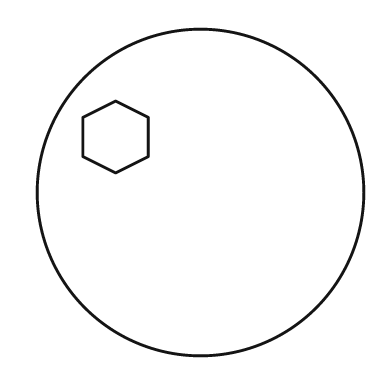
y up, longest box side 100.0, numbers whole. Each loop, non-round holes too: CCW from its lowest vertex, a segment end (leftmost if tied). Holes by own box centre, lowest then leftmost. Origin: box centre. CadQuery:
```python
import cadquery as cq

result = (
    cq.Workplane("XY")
    .moveTo(0.0, 0.0)
    .circle(50.0)
    .moveTo(-26.0, 6.0)
    .lineTo(-16.0, 11.0)
    .lineTo(-16.0, 23.0)
    .lineTo(-26.0, 28.0)
    .lineTo(-36.0, 23.0)
    .lineTo(-36.0, 11.0)
    .close()
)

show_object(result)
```